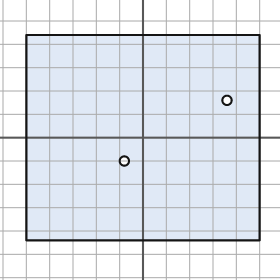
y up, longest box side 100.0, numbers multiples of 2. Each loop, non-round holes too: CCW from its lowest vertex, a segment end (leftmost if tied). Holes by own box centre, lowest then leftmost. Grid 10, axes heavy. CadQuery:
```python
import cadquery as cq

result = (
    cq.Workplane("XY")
    .moveTo(-50.0, -44.0)
    .lineTo(50.0, -44.0)
    .lineTo(50.0, 44.0)
    .lineTo(-50.0, 44.0)
    .close()
    .moveTo(-8.0, -10.0)
    .circle(2.0)
    .moveTo(36.0, 16.0)
    .circle(2.0)
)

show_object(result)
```